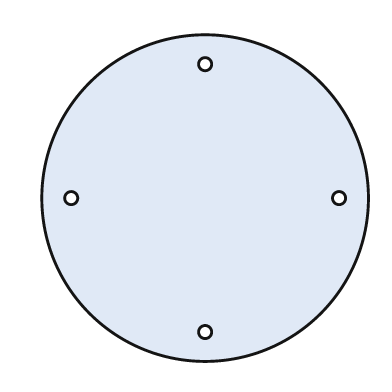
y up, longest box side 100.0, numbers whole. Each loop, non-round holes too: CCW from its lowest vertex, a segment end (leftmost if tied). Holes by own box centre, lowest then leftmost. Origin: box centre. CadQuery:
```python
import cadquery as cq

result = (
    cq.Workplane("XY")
    .moveTo(0.0, 0.0)
    .circle(50.0)
    .moveTo(0.0, -41.0)
    .circle(2.0)
    .moveTo(-41.0, 0.0)
    .circle(2.0)
    .moveTo(41.0, 0.0)
    .circle(2.0)
    .moveTo(0.0, 41.0)
    .circle(2.0)
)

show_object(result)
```